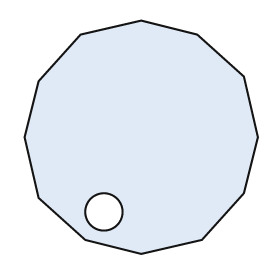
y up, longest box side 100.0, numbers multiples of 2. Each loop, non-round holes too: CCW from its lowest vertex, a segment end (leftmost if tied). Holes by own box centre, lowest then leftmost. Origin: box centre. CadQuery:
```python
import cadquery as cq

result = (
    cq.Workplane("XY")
    .moveTo(0.0, -50.0)
    .lineTo(26.0, -44.0)
    .lineTo(44.0, -24.0)
    .lineTo(50.0, 0.0)
    .lineTo(44.0, 26.0)
    .lineTo(24.0, 44.0)
    .lineTo(0.0, 50.0)
    .lineTo(-26.0, 44.0)
    .lineTo(-44.0, 24.0)
    .lineTo(-50.0, 0.0)
    .lineTo(-44.0, -26.0)
    .lineTo(-24.0, -44.0)
    .close()
    .moveTo(-16.0, -32.0)
    .circle(8.0)
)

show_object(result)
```